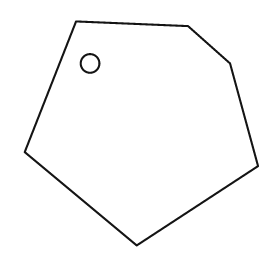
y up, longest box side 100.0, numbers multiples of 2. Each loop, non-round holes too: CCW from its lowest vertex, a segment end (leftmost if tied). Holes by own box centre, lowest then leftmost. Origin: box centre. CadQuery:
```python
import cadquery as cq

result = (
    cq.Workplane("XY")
    .moveTo(-2.0, -48.0)
    .lineTo(50.0, -14.0)
    .lineTo(38.0, 30.0)
    .lineTo(20.0, 46.0)
    .lineTo(-28.0, 48.0)
    .lineTo(-50.0, -8.0)
    .close()
    .moveTo(-22.0, 30.0)
    .circle(4.0)
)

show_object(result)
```